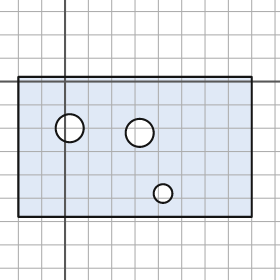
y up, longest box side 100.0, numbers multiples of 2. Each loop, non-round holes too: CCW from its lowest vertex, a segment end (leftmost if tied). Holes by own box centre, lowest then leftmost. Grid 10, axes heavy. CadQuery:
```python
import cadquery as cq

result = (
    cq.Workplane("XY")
    .moveTo(-20.0, -58.0)
    .lineTo(80.0, -58.0)
    .lineTo(80.0, 2.0)
    .lineTo(-20.0, 2.0)
    .close()
    .moveTo(42.0, -48.0)
    .circle(4.0)
    .moveTo(32.0, -22.0)
    .circle(6.0)
    .moveTo(2.0, -20.0)
    .circle(6.0)
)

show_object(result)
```